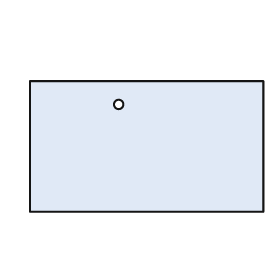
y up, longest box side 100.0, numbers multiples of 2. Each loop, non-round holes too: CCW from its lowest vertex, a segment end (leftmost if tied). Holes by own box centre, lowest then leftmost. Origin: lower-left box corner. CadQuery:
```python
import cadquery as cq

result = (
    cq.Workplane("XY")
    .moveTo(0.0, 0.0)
    .lineTo(100.0, 0.0)
    .lineTo(100.0, 56.0)
    .lineTo(0.0, 56.0)
    .close()
    .moveTo(38.0, 46.0)
    .circle(2.0)
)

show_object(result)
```